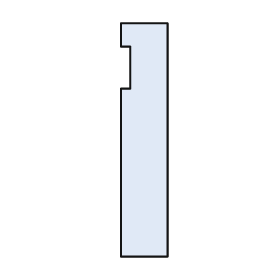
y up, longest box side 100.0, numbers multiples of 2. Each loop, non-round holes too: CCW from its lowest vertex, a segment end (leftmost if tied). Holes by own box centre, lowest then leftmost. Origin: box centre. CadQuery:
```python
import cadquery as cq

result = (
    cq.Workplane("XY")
    .moveTo(-10.0, -50.0)
    .lineTo(10.0, -50.0)
    .lineTo(10.0, 50.0)
    .lineTo(-10.0, 50.0)
    .lineTo(-10.0, 40.0)
    .lineTo(-6.0, 40.0)
    .lineTo(-6.0, 22.0)
    .lineTo(-10.0, 22.0)
    .close()
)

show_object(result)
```